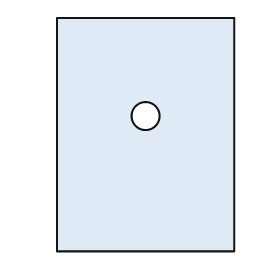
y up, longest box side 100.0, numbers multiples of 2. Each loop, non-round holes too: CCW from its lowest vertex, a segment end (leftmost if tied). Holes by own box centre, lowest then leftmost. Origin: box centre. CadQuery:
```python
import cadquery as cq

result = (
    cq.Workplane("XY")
    .moveTo(-38.0, -50.0)
    .lineTo(38.0, -50.0)
    .lineTo(38.0, 50.0)
    .lineTo(-38.0, 50.0)
    .close()
    .moveTo(0.0, 8.0)
    .circle(6.0)
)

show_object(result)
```